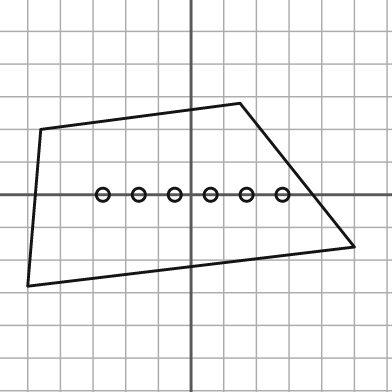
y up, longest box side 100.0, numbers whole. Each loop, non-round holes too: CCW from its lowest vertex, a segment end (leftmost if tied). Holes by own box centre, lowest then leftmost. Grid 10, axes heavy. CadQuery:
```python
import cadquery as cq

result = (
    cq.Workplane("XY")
    .moveTo(-50.0, -28.0)
    .lineTo(50.0, -16.0)
    .lineTo(15.0, 28.0)
    .lineTo(-46.0, 20.0)
    .close()
    .moveTo(-27.0, 0.0)
    .circle(2.0)
    .moveTo(-16.0, 0.0)
    .circle(2.0)
    .moveTo(-5.0, 0.0)
    .circle(2.0)
    .moveTo(6.0, 0.0)
    .circle(2.0)
    .moveTo(17.0, 0.0)
    .circle(2.0)
    .moveTo(28.0, 0.0)
    .circle(2.0)
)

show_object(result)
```